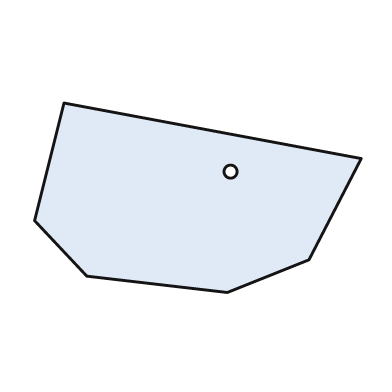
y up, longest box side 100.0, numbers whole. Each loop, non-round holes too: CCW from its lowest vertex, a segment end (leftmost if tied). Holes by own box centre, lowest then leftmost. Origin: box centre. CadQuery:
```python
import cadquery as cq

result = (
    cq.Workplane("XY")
    .moveTo(9.0, -29.0)
    .lineTo(34.0, -19.0)
    .lineTo(50.0, 12.0)
    .lineTo(-41.0, 29.0)
    .lineTo(-50.0, -7.0)
    .lineTo(-34.0, -24.0)
    .close()
    .moveTo(10.0, 8.0)
    .circle(2.0)
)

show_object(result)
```